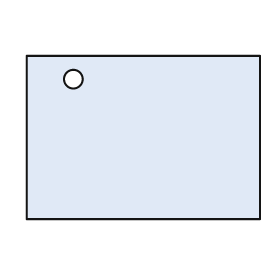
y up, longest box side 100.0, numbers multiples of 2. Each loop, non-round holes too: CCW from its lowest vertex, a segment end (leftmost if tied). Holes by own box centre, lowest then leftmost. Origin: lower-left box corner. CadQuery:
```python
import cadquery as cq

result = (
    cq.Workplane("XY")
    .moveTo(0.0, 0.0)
    .lineTo(100.0, 0.0)
    .lineTo(100.0, 70.0)
    .lineTo(0.0, 70.0)
    .close()
    .moveTo(20.0, 60.0)
    .circle(4.0)
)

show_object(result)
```